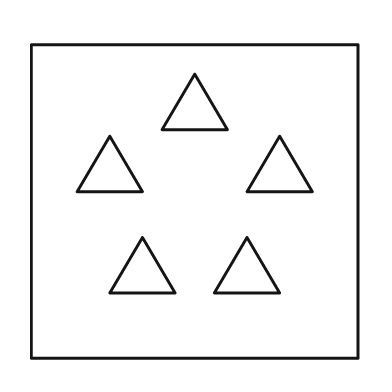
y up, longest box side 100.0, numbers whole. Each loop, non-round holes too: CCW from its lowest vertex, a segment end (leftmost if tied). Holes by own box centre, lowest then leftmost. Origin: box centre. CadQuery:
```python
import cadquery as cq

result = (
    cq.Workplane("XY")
    .moveTo(-50.0, -48.0)
    .lineTo(50.0, -48.0)
    .lineTo(50.0, 48.0)
    .lineTo(-50.0, 48.0)
    .close()
    .moveTo(-26.0, -28.0)
    .lineTo(-6.0, -28.0)
    .lineTo(-16.0, -11.0)
    .close()
    .moveTo(6.0, -28.0)
    .lineTo(26.0, -28.0)
    .lineTo(16.0, -11.0)
    .close()
    .moveTo(-36.0, 3.0)
    .lineTo(-16.0, 3.0)
    .lineTo(-26.0, 20.0)
    .close()
    .moveTo(16.0, 3.0)
    .lineTo(36.0, 3.0)
    .lineTo(26.0, 20.0)
    .close()
    .moveTo(-10.0, 22.0)
    .lineTo(10.0, 22.0)
    .lineTo(0.0, 39.0)
    .close()
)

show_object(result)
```